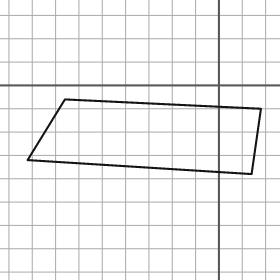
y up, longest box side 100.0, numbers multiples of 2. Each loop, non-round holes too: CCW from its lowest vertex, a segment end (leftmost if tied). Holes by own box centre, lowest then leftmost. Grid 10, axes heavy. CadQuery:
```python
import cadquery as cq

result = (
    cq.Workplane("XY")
    .moveTo(14.0, -38.0)
    .lineTo(18.0, -10.0)
    .lineTo(-66.0, -6.0)
    .lineTo(-82.0, -32.0)
    .close()
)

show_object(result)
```